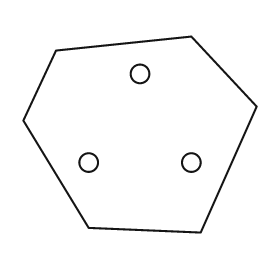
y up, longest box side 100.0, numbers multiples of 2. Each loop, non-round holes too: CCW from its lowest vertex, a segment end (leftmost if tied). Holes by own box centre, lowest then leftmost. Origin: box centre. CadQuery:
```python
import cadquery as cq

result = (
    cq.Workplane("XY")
    .moveTo(26.0, -42.0)
    .lineTo(50.0, 12.0)
    .lineTo(22.0, 42.0)
    .lineTo(-36.0, 36.0)
    .lineTo(-50.0, 6.0)
    .lineTo(-22.0, -40.0)
    .close()
    .moveTo(-22.0, -12.0)
    .circle(4.0)
    .moveTo(22.0, -12.0)
    .circle(4.0)
    .moveTo(0.0, 26.0)
    .circle(4.0)
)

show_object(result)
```